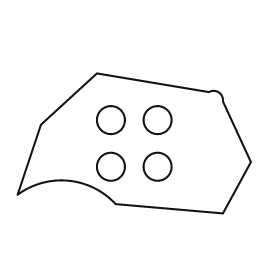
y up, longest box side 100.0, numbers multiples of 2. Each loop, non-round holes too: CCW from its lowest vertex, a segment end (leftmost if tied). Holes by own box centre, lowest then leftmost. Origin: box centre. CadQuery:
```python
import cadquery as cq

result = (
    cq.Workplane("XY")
    .moveTo(38.0, -30.0)
    .lineTo(50.0, -8.0)
    .lineTo(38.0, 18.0)
    .threePointArc((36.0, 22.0), (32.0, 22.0))
    .lineTo(-16.0, 30.0)
    .lineTo(-40.0, 8.0)
    .lineTo(-50.0, -22.0)
    .threePointArc((-28.0, -16.0), (-8.0, -26.0))
    .close()
    .moveTo(-10.0, -10.0)
    .circle(6.0)
    .moveTo(10.0, -10.0)
    .circle(6.0)
    .moveTo(-10.0, 10.0)
    .circle(6.0)
    .moveTo(10.0, 10.0)
    .circle(6.0)
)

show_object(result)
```